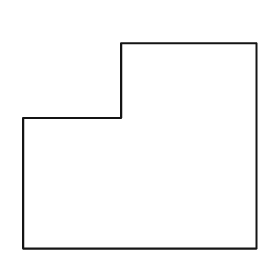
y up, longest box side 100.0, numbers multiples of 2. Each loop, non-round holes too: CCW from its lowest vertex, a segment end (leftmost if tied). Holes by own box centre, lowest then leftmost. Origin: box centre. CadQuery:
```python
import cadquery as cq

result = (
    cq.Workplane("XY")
    .moveTo(-50.0, -44.0)
    .lineTo(50.0, -44.0)
    .lineTo(50.0, 44.0)
    .lineTo(-8.0, 44.0)
    .lineTo(-8.0, 12.0)
    .lineTo(-50.0, 12.0)
    .close()
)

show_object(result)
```